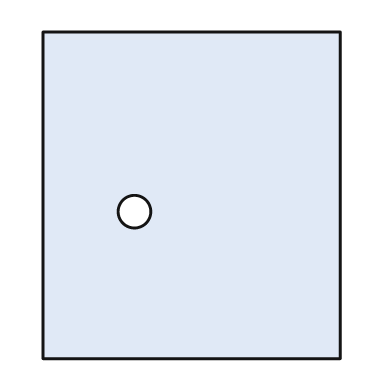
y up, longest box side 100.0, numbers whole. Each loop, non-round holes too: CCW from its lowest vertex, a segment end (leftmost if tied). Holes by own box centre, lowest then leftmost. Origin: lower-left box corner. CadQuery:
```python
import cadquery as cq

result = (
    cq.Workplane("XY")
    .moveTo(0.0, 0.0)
    .lineTo(91.0, 0.0)
    .lineTo(91.0, 100.0)
    .lineTo(0.0, 100.0)
    .close()
    .moveTo(28.0, 45.0)
    .circle(5.0)
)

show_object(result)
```